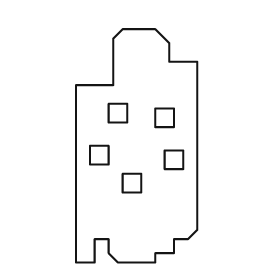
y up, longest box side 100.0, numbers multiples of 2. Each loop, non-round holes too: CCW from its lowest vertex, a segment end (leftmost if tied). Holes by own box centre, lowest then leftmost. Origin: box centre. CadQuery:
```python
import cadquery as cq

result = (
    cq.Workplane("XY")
    .moveTo(-26.0, -50.0)
    .lineTo(-18.0, -50.0)
    .lineTo(-18.0, -40.0)
    .lineTo(-12.0, -40.0)
    .lineTo(-12.0, -46.0)
    .lineTo(-8.0, -50.0)
    .lineTo(8.0, -50.0)
    .lineTo(8.0, -46.0)
    .lineTo(16.0, -46.0)
    .lineTo(16.0, -40.0)
    .lineTo(22.0, -40.0)
    .lineTo(26.0, -36.0)
    .lineTo(26.0, 36.0)
    .lineTo(14.0, 36.0)
    .lineTo(14.0, 44.0)
    .lineTo(8.0, 50.0)
    .lineTo(-6.0, 50.0)
    .lineTo(-10.0, 46.0)
    .lineTo(-10.0, 26.0)
    .lineTo(-26.0, 26.0)
    .close()
    .moveTo(-6.0, -20.0)
    .lineTo(2.0, -20.0)
    .lineTo(2.0, -12.0)
    .lineTo(-6.0, -12.0)
    .close()
    .moveTo(12.0, -10.0)
    .lineTo(20.0, -10.0)
    .lineTo(20.0, -2.0)
    .lineTo(12.0, -2.0)
    .close()
    .moveTo(-20.0, -8.0)
    .lineTo(-12.0, -8.0)
    .lineTo(-12.0, 0.0)
    .lineTo(-20.0, 0.0)
    .close()
    .moveTo(8.0, 8.0)
    .lineTo(16.0, 8.0)
    .lineTo(16.0, 16.0)
    .lineTo(8.0, 16.0)
    .close()
    .moveTo(-12.0, 10.0)
    .lineTo(-4.0, 10.0)
    .lineTo(-4.0, 18.0)
    .lineTo(-12.0, 18.0)
    .close()
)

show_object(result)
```